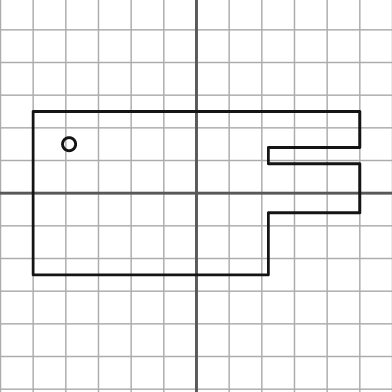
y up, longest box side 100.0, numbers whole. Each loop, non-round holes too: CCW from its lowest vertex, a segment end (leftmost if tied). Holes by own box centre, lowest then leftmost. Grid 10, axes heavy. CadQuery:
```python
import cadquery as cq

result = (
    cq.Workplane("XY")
    .moveTo(-50.0, -25.0)
    .lineTo(22.0, -25.0)
    .lineTo(22.0, -6.0)
    .lineTo(50.0, -6.0)
    .lineTo(50.0, 9.0)
    .lineTo(22.0, 9.0)
    .lineTo(22.0, 14.0)
    .lineTo(50.0, 14.0)
    .lineTo(50.0, 25.0)
    .lineTo(-50.0, 25.0)
    .close()
    .moveTo(-39.0, 15.0)
    .circle(2.0)
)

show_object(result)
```